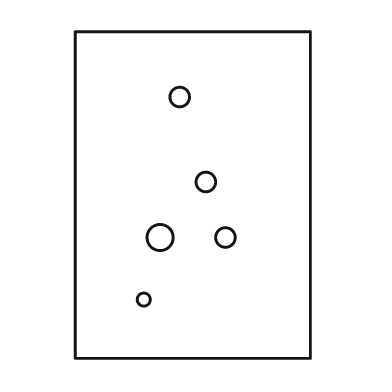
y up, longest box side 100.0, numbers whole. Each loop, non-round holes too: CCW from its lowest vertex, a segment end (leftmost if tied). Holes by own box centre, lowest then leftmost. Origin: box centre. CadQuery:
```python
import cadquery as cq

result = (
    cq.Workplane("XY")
    .moveTo(-36.0, -50.0)
    .lineTo(36.0, -50.0)
    .lineTo(36.0, 50.0)
    .lineTo(-36.0, 50.0)
    .close()
    .moveTo(-15.0, -32.0)
    .circle(2.0)
    .moveTo(-10.0, -13.0)
    .circle(4.0)
    .moveTo(10.0, -13.0)
    .circle(3.0)
    .moveTo(4.0, 4.0)
    .circle(3.0)
    .moveTo(-4.0, 30.0)
    .circle(3.0)
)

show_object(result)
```